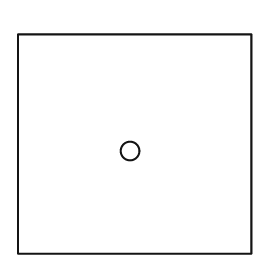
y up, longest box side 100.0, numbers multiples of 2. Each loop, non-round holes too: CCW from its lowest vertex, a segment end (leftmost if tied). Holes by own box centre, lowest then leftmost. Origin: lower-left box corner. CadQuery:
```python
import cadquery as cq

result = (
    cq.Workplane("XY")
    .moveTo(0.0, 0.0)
    .lineTo(100.0, 0.0)
    .lineTo(100.0, 94.0)
    .lineTo(0.0, 94.0)
    .close()
    .moveTo(48.0, 44.0)
    .circle(4.0)
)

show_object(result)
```